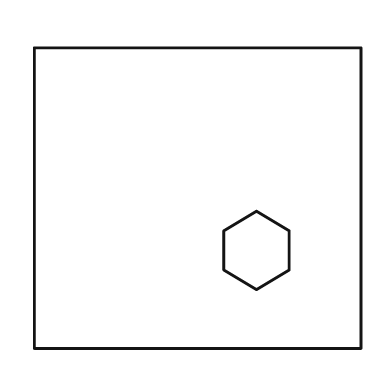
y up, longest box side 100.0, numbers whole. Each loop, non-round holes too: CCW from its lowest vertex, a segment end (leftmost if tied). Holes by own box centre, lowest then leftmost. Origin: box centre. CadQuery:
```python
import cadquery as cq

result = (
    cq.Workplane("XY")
    .moveTo(-50.0, -46.0)
    .lineTo(50.0, -46.0)
    .lineTo(50.0, 46.0)
    .lineTo(-50.0, 46.0)
    .close()
    .moveTo(18.0, -28.0)
    .lineTo(28.0, -22.0)
    .lineTo(28.0, -10.0)
    .lineTo(18.0, -4.0)
    .lineTo(8.0, -10.0)
    .lineTo(8.0, -22.0)
    .close()
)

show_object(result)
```